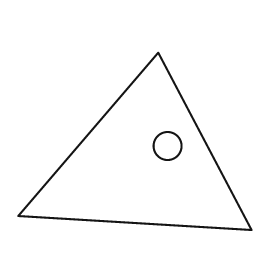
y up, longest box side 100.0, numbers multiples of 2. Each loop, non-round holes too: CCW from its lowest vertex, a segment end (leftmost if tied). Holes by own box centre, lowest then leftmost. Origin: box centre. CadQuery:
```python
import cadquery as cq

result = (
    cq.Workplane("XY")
    .moveTo(50.0, -38.0)
    .lineTo(10.0, 38.0)
    .lineTo(-50.0, -32.0)
    .close()
    .moveTo(14.0, -2.0)
    .circle(6.0)
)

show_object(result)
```